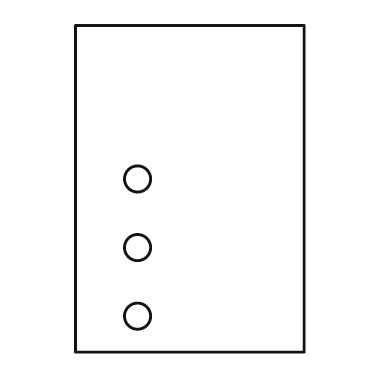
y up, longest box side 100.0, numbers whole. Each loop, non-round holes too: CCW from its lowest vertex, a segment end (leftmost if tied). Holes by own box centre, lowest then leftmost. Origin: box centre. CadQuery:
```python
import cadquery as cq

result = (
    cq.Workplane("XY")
    .moveTo(-35.0, -50.0)
    .lineTo(35.0, -50.0)
    .lineTo(35.0, 50.0)
    .lineTo(-35.0, 50.0)
    .close()
    .moveTo(-16.0, -39.0)
    .circle(4.0)
    .moveTo(-16.0, -18.0)
    .circle(4.0)
    .moveTo(-16.0, 3.0)
    .circle(4.0)
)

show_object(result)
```